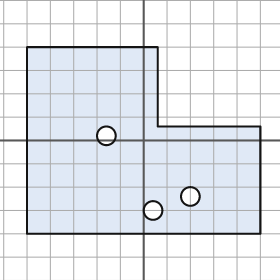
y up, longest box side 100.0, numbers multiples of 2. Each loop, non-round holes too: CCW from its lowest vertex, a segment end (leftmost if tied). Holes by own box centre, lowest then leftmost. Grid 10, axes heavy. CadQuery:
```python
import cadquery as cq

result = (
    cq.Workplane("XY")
    .moveTo(-50.0, -40.0)
    .lineTo(50.0, -40.0)
    .lineTo(50.0, 6.0)
    .lineTo(6.0, 6.0)
    .lineTo(6.0, 40.0)
    .lineTo(-50.0, 40.0)
    .close()
    .moveTo(4.0, -30.0)
    .circle(4.0)
    .moveTo(20.0, -24.0)
    .circle(4.0)
    .moveTo(-16.0, 2.0)
    .circle(4.0)
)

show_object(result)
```